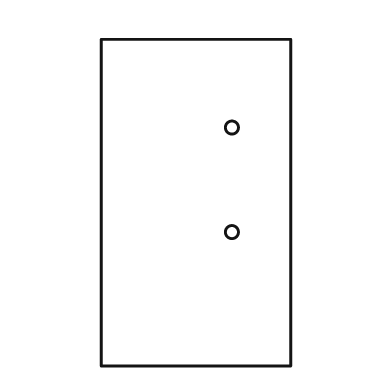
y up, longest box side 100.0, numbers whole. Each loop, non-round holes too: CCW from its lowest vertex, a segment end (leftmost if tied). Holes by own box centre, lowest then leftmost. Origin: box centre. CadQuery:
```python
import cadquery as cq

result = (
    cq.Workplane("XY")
    .moveTo(-29.0, -50.0)
    .lineTo(29.0, -50.0)
    .lineTo(29.0, 50.0)
    .lineTo(-29.0, 50.0)
    .close()
    .moveTo(11.0, -9.0)
    .circle(2.0)
    .moveTo(11.0, 23.0)
    .circle(2.0)
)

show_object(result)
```